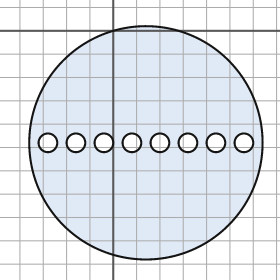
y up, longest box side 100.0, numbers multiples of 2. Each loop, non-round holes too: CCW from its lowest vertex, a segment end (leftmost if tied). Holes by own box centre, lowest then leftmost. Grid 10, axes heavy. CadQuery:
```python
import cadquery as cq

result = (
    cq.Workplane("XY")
    .moveTo(14.0, -48.0)
    .circle(50.0)
    .moveTo(-28.0, -48.0)
    .circle(4.0)
    .moveTo(-16.0, -48.0)
    .circle(4.0)
    .moveTo(-4.0, -48.0)
    .circle(4.0)
    .moveTo(8.0, -48.0)
    .circle(4.0)
    .moveTo(20.0, -48.0)
    .circle(4.0)
    .moveTo(32.0, -48.0)
    .circle(4.0)
    .moveTo(44.0, -48.0)
    .circle(4.0)
    .moveTo(56.0, -48.0)
    .circle(4.0)
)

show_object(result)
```